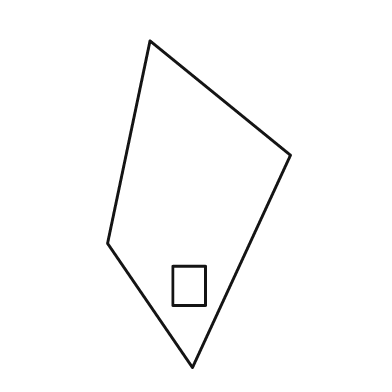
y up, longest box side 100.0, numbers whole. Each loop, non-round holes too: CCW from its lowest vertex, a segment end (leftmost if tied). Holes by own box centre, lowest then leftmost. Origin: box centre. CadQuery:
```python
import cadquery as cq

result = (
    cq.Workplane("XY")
    .moveTo(-2.0, -50.0)
    .lineTo(28.0, 15.0)
    .lineTo(-15.0, 50.0)
    .lineTo(-28.0, -12.0)
    .close()
    .moveTo(-8.0, -31.0)
    .lineTo(2.0, -31.0)
    .lineTo(2.0, -19.0)
    .lineTo(-8.0, -19.0)
    .close()
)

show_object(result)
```